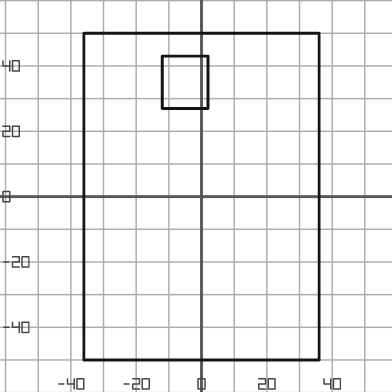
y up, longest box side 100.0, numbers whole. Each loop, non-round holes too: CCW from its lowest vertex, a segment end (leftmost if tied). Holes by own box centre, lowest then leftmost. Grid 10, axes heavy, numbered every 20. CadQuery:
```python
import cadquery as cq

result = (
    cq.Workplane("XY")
    .moveTo(-36.0, -50.0)
    .lineTo(36.0, -50.0)
    .lineTo(36.0, 50.0)
    .lineTo(-36.0, 50.0)
    .close()
    .moveTo(-12.0, 27.0)
    .lineTo(2.0, 27.0)
    .lineTo(2.0, 43.0)
    .lineTo(-12.0, 43.0)
    .close()
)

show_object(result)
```